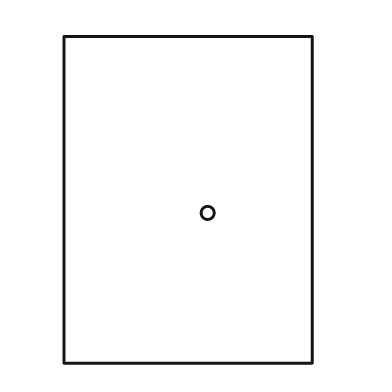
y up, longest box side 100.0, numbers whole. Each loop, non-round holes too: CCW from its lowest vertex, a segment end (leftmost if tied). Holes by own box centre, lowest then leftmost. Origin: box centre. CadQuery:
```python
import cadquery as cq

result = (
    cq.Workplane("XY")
    .moveTo(-38.0, -50.0)
    .lineTo(38.0, -50.0)
    .lineTo(38.0, 50.0)
    .lineTo(-38.0, 50.0)
    .close()
    .moveTo(6.0, -4.0)
    .circle(2.0)
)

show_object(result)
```